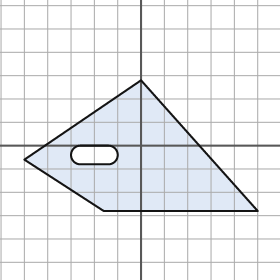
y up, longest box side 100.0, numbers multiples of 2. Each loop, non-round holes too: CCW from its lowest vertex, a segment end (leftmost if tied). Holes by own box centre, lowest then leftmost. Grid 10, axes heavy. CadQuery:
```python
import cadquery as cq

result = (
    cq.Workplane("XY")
    .moveTo(-16.0, -28.0)
    .lineTo(50.0, -28.0)
    .lineTo(0.0, 28.0)
    .lineTo(-50.0, -6.0)
    .close()
    .moveTo(-26.0, -8.0)
    .lineTo(-14.0, -8.0)
    .threePointArc((-10.0, -4.0), (-14.0, 0.0))
    .lineTo(-26.0, 0.0)
    .threePointArc((-30.0, -4.0), (-26.0, -8.0))
    .close()
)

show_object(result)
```